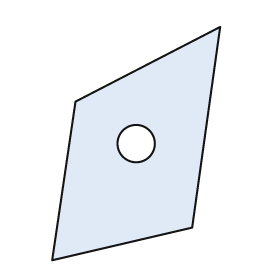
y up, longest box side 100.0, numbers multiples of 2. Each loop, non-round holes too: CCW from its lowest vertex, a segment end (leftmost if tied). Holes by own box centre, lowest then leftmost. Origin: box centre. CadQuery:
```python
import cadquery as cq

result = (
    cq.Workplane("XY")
    .moveTo(-36.0, -50.0)
    .lineTo(24.0, -36.0)
    .lineTo(36.0, 50.0)
    .lineTo(-26.0, 18.0)
    .close()
    .moveTo(0.0, 0.0)
    .circle(8.0)
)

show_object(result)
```